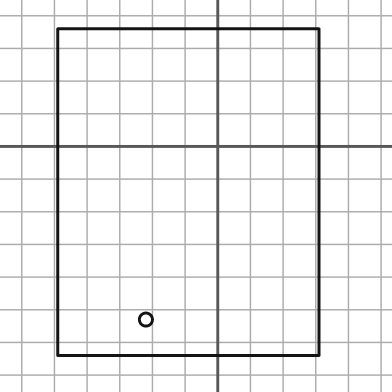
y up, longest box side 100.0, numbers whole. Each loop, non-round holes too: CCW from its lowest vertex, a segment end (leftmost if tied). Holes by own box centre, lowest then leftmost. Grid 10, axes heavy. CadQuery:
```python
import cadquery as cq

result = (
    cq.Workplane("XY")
    .moveTo(-49.0, -64.0)
    .lineTo(31.0, -64.0)
    .lineTo(31.0, 36.0)
    .lineTo(-49.0, 36.0)
    .close()
    .moveTo(-22.0, -53.0)
    .circle(2.0)
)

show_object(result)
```